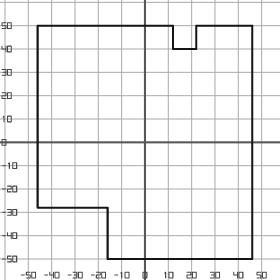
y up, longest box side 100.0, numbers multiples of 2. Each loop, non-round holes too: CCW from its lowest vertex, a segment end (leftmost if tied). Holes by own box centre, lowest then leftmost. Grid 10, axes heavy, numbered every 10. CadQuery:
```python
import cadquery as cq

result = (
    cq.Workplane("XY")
    .moveTo(-16.0, -50.0)
    .lineTo(46.0, -50.0)
    .lineTo(46.0, 50.0)
    .lineTo(22.0, 50.0)
    .lineTo(22.0, 40.0)
    .lineTo(12.0, 40.0)
    .lineTo(12.0, 50.0)
    .lineTo(-46.0, 50.0)
    .lineTo(-46.0, -28.0)
    .lineTo(-16.0, -28.0)
    .close()
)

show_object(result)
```